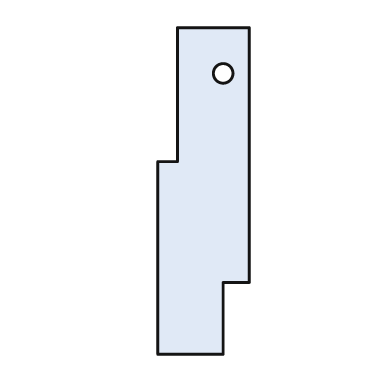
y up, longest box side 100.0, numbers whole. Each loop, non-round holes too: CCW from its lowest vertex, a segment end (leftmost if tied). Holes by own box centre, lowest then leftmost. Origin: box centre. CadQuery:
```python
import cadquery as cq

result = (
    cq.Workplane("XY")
    .moveTo(-14.0, -50.0)
    .lineTo(6.0, -50.0)
    .lineTo(6.0, -28.0)
    .lineTo(14.0, -28.0)
    .lineTo(14.0, 50.0)
    .lineTo(-8.0, 50.0)
    .lineTo(-8.0, 9.0)
    .lineTo(-14.0, 9.0)
    .close()
    .moveTo(6.0, 36.0)
    .circle(3.0)
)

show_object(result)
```